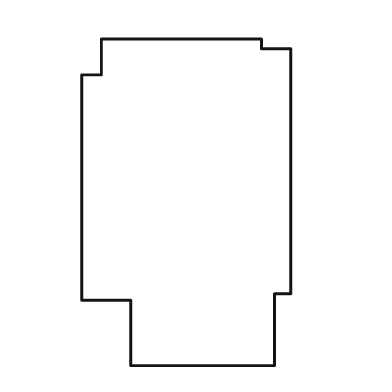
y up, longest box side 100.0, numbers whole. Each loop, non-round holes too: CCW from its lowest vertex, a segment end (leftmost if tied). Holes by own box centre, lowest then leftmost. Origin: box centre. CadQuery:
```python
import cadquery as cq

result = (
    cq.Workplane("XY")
    .moveTo(-17.0, -50.0)
    .lineTo(27.0, -50.0)
    .lineTo(27.0, -28.0)
    .lineTo(32.0, -28.0)
    .lineTo(32.0, 47.0)
    .lineTo(23.0, 47.0)
    .lineTo(23.0, 50.0)
    .lineTo(-26.0, 50.0)
    .lineTo(-26.0, 39.0)
    .lineTo(-32.0, 39.0)
    .lineTo(-32.0, -30.0)
    .lineTo(-17.0, -30.0)
    .close()
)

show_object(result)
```